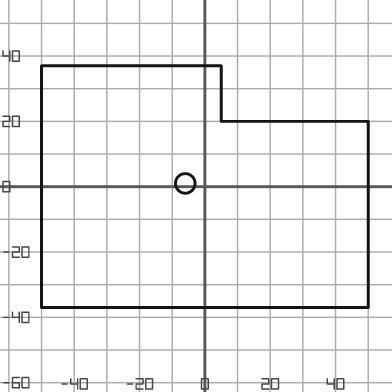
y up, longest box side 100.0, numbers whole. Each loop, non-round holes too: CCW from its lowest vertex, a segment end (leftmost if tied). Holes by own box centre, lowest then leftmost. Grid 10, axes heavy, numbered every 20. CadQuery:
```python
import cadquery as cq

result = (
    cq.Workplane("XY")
    .moveTo(-50.0, -37.0)
    .lineTo(50.0, -37.0)
    .lineTo(50.0, 20.0)
    .lineTo(5.0, 20.0)
    .lineTo(5.0, 37.0)
    .lineTo(-50.0, 37.0)
    .close()
    .moveTo(-6.0, 1.0)
    .circle(3.0)
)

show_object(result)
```